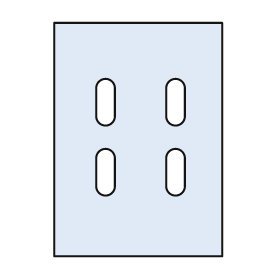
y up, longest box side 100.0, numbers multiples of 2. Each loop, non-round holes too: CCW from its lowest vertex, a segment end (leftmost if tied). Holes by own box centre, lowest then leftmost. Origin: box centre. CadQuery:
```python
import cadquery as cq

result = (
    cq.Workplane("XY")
    .moveTo(-36.0, -50.0)
    .lineTo(36.0, -50.0)
    .lineTo(36.0, 50.0)
    .lineTo(-36.0, 50.0)
    .close()
    .moveTo(-18.0, -20.0)
    .threePointArc((-14.0, -24.0), (-10.0, -20.0))
    .lineTo(-10.0, -8.0)
    .threePointArc((-14.0, -4.0), (-18.0, -8.0))
    .close()
    .moveTo(12.0, -20.0)
    .threePointArc((16.0, -24.0), (20.0, -20.0))
    .lineTo(20.0, -8.0)
    .threePointArc((16.0, -4.0), (12.0, -8.0))
    .close()
    .moveTo(-18.0, 10.0)
    .threePointArc((-14.0, 6.0), (-10.0, 10.0))
    .lineTo(-10.0, 22.0)
    .threePointArc((-14.0, 26.0), (-18.0, 22.0))
    .close()
    .moveTo(12.0, 10.0)
    .threePointArc((16.0, 6.0), (20.0, 10.0))
    .lineTo(20.0, 22.0)
    .threePointArc((16.0, 26.0), (12.0, 22.0))
    .close()
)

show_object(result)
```